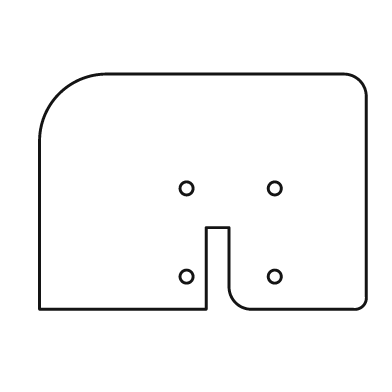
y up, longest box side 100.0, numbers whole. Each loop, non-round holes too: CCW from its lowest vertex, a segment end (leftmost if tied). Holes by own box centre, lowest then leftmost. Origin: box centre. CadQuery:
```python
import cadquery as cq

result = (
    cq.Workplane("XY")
    .moveTo(-50.0, -36.0)
    .lineTo(1.0, -36.0)
    .lineTo(1.0, -11.0)
    .lineTo(8.0, -11.0)
    .lineTo(8.0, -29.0)
    .threePointArc((10.0, -34.0), (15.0, -36.0))
    .lineTo(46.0, -36.0)
    .threePointArc((49.0, -35.0), (50.0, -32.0))
    .lineTo(50.0, 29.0)
    .threePointArc((48.0, 34.0), (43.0, 36.0))
    .lineTo(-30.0, 36.0)
    .threePointArc((-44.0, 30.0), (-50.0, 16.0))
    .close()
    .moveTo(-5.0, -26.0)
    .circle(2.0)
    .moveTo(22.0, -26.0)
    .circle(2.0)
    .moveTo(-5.0, 1.0)
    .circle(2.0)
    .moveTo(22.0, 1.0)
    .circle(2.0)
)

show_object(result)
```